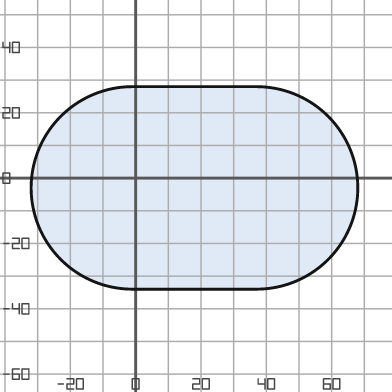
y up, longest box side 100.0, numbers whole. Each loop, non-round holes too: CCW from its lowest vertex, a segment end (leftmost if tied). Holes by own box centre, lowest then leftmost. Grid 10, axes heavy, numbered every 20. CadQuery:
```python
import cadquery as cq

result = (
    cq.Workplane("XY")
    .moveTo(-1.0, -34.0)
    .lineTo(37.0, -34.0)
    .threePointArc((68.0, -3.0), (37.0, 28.0))
    .lineTo(-1.0, 28.0)
    .threePointArc((-32.0, -3.0), (-1.0, -34.0))
    .close()
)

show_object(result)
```